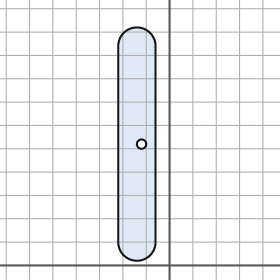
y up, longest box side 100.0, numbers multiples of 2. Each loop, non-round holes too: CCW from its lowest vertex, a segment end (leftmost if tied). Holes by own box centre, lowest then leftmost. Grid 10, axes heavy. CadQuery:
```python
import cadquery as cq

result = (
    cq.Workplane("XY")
    .moveTo(-22.0, 10.0)
    .threePointArc((-14.0, 2.0), (-6.0, 10.0))
    .lineTo(-6.0, 94.0)
    .threePointArc((-14.0, 102.0), (-22.0, 94.0))
    .close()
    .moveTo(-12.0, 52.0)
    .circle(2.0)
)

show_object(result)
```